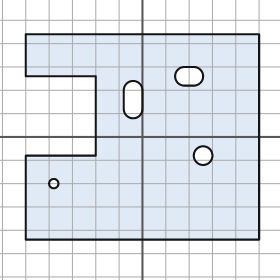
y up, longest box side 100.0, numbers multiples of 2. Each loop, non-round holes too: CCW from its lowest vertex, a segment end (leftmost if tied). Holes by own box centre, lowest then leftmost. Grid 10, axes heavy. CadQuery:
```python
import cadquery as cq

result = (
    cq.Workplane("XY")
    .moveTo(-50.0, -44.0)
    .lineTo(50.0, -44.0)
    .lineTo(50.0, 44.0)
    .lineTo(-50.0, 44.0)
    .lineTo(-50.0, 26.0)
    .lineTo(-20.0, 26.0)
    .lineTo(-20.0, -8.0)
    .lineTo(-50.0, -8.0)
    .close()
    .moveTo(-38.0, -20.0)
    .circle(2.0)
    .moveTo(26.0, -8.0)
    .circle(4.0)
    .moveTo(-8.0, 12.0)
    .threePointArc((-4.0, 8.0), (0.0, 12.0))
    .lineTo(0.0, 20.0)
    .threePointArc((-4.0, 24.0), (-8.0, 20.0))
    .close()
    .moveTo(18.0, 22.0)
    .lineTo(22.0, 22.0)
    .threePointArc((26.0, 26.0), (22.0, 30.0))
    .lineTo(18.0, 30.0)
    .threePointArc((14.0, 26.0), (18.0, 22.0))
    .close()
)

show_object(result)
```